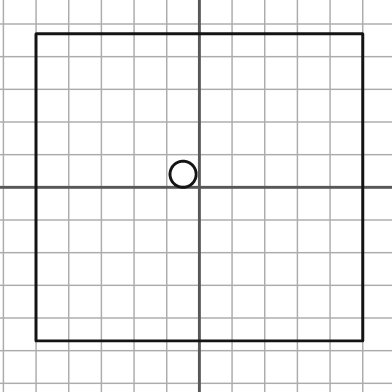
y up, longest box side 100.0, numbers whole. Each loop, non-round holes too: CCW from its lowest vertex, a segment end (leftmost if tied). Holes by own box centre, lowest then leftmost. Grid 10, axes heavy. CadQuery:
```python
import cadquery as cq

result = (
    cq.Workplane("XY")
    .moveTo(-50.0, -47.0)
    .lineTo(50.0, -47.0)
    .lineTo(50.0, 47.0)
    .lineTo(-50.0, 47.0)
    .close()
    .moveTo(-5.0, 4.0)
    .circle(4.0)
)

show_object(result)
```